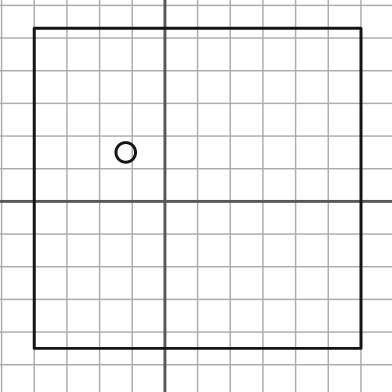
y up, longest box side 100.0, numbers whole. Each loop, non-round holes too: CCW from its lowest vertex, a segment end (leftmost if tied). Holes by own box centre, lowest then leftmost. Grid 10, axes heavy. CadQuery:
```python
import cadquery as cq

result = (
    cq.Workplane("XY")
    .moveTo(-40.0, -45.0)
    .lineTo(60.0, -45.0)
    .lineTo(60.0, 53.0)
    .lineTo(-40.0, 53.0)
    .close()
    .moveTo(-12.0, 15.0)
    .circle(3.0)
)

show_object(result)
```